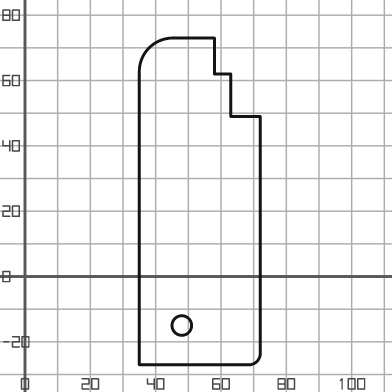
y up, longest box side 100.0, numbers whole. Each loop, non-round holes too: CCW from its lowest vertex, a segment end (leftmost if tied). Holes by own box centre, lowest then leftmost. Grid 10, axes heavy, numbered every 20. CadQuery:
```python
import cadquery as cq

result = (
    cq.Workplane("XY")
    .moveTo(35.0, -27.0)
    .lineTo(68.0, -27.0)
    .threePointArc((71.0, -26.0), (72.0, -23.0))
    .lineTo(72.0, 49.0)
    .lineTo(63.0, 49.0)
    .lineTo(63.0, 62.0)
    .lineTo(58.0, 62.0)
    .lineTo(58.0, 73.0)
    .lineTo(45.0, 73.0)
    .threePointArc((38.0, 70.0), (35.0, 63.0))
    .close()
    .moveTo(48.0, -15.0)
    .circle(3.0)
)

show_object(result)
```